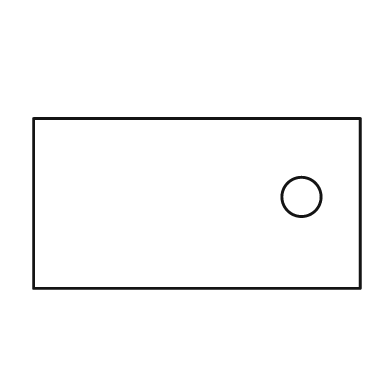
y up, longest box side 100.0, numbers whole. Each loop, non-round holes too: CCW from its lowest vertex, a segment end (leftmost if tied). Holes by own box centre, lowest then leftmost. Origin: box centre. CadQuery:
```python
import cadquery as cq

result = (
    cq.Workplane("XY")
    .moveTo(-50.0, -26.0)
    .lineTo(50.0, -26.0)
    .lineTo(50.0, 26.0)
    .lineTo(-50.0, 26.0)
    .close()
    .moveTo(32.0, 2.0)
    .circle(6.0)
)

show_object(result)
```